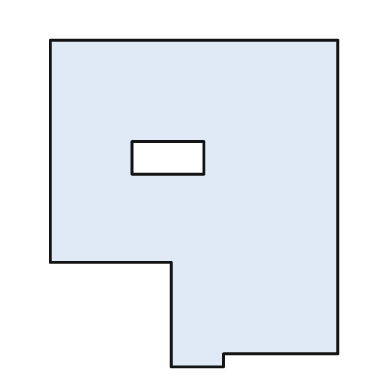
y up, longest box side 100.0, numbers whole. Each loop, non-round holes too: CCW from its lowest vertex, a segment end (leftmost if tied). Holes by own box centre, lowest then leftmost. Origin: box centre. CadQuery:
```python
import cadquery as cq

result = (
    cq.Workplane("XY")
    .moveTo(-7.0, -50.0)
    .lineTo(9.0, -50.0)
    .lineTo(9.0, -46.0)
    .lineTo(44.0, -46.0)
    .lineTo(44.0, 50.0)
    .lineTo(-44.0, 50.0)
    .lineTo(-44.0, -18.0)
    .lineTo(-7.0, -18.0)
    .close()
    .moveTo(-19.0, 9.0)
    .lineTo(3.0, 9.0)
    .lineTo(3.0, 19.0)
    .lineTo(-19.0, 19.0)
    .close()
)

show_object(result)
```